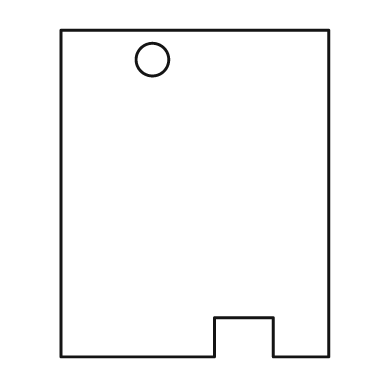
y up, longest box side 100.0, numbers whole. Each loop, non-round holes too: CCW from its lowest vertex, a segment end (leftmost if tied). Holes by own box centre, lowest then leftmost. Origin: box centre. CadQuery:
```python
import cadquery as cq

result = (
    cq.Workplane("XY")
    .moveTo(-41.0, -50.0)
    .lineTo(6.0, -50.0)
    .lineTo(6.0, -38.0)
    .lineTo(24.0, -38.0)
    .lineTo(24.0, -50.0)
    .lineTo(41.0, -50.0)
    .lineTo(41.0, 50.0)
    .lineTo(-41.0, 50.0)
    .close()
    .moveTo(-13.0, 41.0)
    .circle(5.0)
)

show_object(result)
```